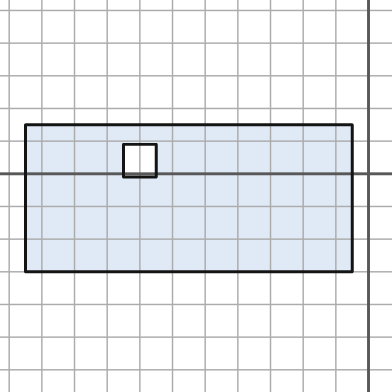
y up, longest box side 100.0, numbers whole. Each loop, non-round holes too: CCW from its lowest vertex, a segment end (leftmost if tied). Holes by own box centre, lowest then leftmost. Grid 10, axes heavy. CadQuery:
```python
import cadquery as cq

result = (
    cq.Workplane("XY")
    .moveTo(-105.0, -30.0)
    .lineTo(-5.0, -30.0)
    .lineTo(-5.0, 15.0)
    .lineTo(-105.0, 15.0)
    .close()
    .moveTo(-75.0, -1.0)
    .lineTo(-65.0, -1.0)
    .lineTo(-65.0, 9.0)
    .lineTo(-75.0, 9.0)
    .close()
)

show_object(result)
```